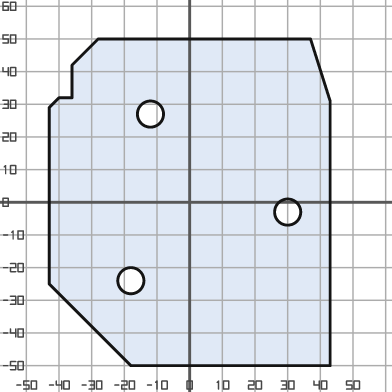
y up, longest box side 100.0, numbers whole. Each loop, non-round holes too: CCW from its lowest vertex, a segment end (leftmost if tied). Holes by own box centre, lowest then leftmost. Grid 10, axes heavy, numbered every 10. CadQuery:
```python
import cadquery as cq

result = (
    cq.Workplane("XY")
    .moveTo(-18.0, -50.0)
    .lineTo(43.0, -50.0)
    .lineTo(43.0, 31.0)
    .lineTo(37.0, 50.0)
    .lineTo(-28.0, 50.0)
    .lineTo(-36.0, 42.0)
    .lineTo(-36.0, 32.0)
    .lineTo(-40.0, 32.0)
    .lineTo(-43.0, 29.0)
    .lineTo(-43.0, -25.0)
    .close()
    .moveTo(-18.0, -24.0)
    .circle(4.0)
    .moveTo(30.0, -3.0)
    .circle(4.0)
    .moveTo(-12.0, 27.0)
    .circle(4.0)
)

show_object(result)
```